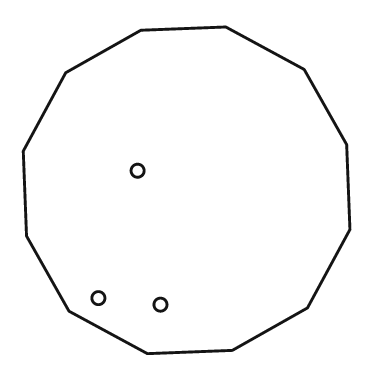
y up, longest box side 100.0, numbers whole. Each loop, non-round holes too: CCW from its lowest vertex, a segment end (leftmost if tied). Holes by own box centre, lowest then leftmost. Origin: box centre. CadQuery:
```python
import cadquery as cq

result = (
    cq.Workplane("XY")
    .moveTo(-12.0, -50.0)
    .lineTo(14.0, -49.0)
    .lineTo(37.0, -36.0)
    .lineTo(50.0, -12.0)
    .lineTo(49.0, 14.0)
    .lineTo(36.0, 37.0)
    .lineTo(12.0, 50.0)
    .lineTo(-14.0, 49.0)
    .lineTo(-37.0, 36.0)
    .lineTo(-50.0, 12.0)
    .lineTo(-49.0, -14.0)
    .lineTo(-36.0, -37.0)
    .close()
    .moveTo(-8.0, -35.0)
    .circle(2.0)
    .moveTo(-27.0, -33.0)
    .circle(2.0)
    .moveTo(-15.0, 6.0)
    .circle(2.0)
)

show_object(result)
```